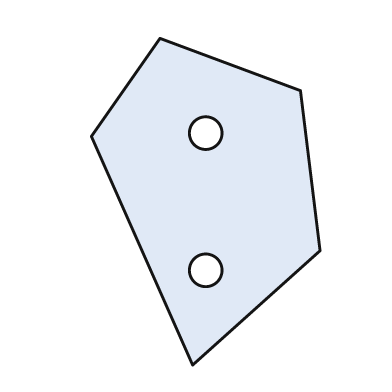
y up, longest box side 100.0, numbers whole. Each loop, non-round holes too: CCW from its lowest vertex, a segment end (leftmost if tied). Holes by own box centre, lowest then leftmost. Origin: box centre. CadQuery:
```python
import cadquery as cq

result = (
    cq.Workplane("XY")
    .moveTo(-4.0, -50.0)
    .lineTo(35.0, -15.0)
    .lineTo(29.0, 34.0)
    .lineTo(-14.0, 50.0)
    .lineTo(-35.0, 20.0)
    .close()
    .moveTo(0.0, -21.0)
    .circle(5.0)
    .moveTo(0.0, 21.0)
    .circle(5.0)
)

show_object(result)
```